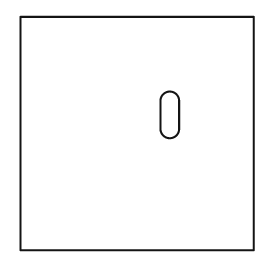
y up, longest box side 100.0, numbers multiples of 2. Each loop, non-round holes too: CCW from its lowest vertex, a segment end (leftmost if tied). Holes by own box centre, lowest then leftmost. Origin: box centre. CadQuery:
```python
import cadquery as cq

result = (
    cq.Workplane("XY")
    .moveTo(-50.0, -50.0)
    .lineTo(50.0, -50.0)
    .lineTo(50.0, 50.0)
    .lineTo(-50.0, 50.0)
    .close()
    .moveTo(10.0, 2.0)
    .threePointArc((14.0, -2.0), (18.0, 2.0))
    .lineTo(18.0, 14.0)
    .threePointArc((14.0, 18.0), (10.0, 14.0))
    .close()
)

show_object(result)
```